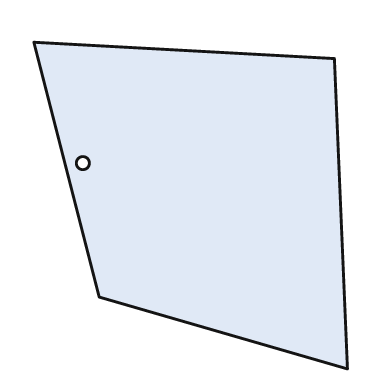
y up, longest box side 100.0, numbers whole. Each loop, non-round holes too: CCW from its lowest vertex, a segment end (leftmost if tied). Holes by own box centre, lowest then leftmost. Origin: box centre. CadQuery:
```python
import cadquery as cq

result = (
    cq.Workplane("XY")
    .moveTo(48.0, -50.0)
    .lineTo(44.0, 45.0)
    .lineTo(-48.0, 50.0)
    .lineTo(-28.0, -28.0)
    .close()
    .moveTo(-33.0, 13.0)
    .circle(2.0)
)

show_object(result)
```